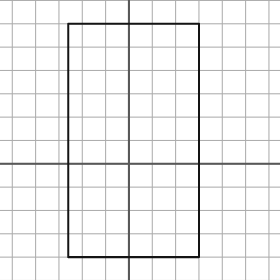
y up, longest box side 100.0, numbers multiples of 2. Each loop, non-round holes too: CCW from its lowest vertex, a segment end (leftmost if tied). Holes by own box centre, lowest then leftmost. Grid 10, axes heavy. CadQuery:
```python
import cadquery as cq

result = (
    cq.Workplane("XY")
    .moveTo(-26.0, -40.0)
    .lineTo(30.0, -40.0)
    .lineTo(30.0, 60.0)
    .lineTo(-26.0, 60.0)
    .close()
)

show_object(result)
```